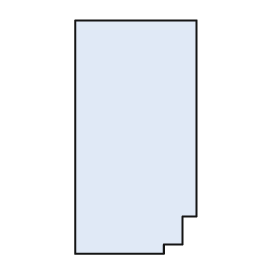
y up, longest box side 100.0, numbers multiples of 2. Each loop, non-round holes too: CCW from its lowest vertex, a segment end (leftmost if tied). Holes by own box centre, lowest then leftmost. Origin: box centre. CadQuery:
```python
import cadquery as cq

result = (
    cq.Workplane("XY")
    .moveTo(-26.0, -50.0)
    .lineTo(12.0, -50.0)
    .lineTo(12.0, -46.0)
    .lineTo(20.0, -46.0)
    .lineTo(20.0, -34.0)
    .lineTo(26.0, -34.0)
    .lineTo(26.0, 50.0)
    .lineTo(-26.0, 50.0)
    .close()
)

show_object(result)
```